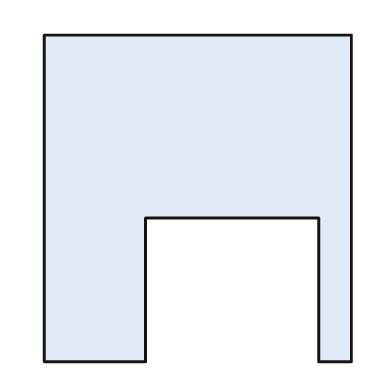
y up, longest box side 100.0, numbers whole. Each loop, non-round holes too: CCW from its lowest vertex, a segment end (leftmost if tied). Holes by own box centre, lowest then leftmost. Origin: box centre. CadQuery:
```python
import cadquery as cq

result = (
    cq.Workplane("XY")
    .moveTo(-47.0, -50.0)
    .lineTo(-16.0, -50.0)
    .lineTo(-16.0, -6.0)
    .lineTo(37.0, -6.0)
    .lineTo(37.0, -50.0)
    .lineTo(47.0, -50.0)
    .lineTo(47.0, 50.0)
    .lineTo(-47.0, 50.0)
    .close()
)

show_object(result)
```